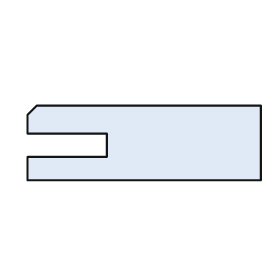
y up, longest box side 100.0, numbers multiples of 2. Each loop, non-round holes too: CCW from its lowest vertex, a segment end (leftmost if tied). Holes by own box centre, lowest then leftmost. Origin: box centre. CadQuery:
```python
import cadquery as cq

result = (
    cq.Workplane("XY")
    .moveTo(-50.0, -16.0)
    .lineTo(50.0, -16.0)
    .lineTo(50.0, 16.0)
    .lineTo(-46.0, 16.0)
    .lineTo(-50.0, 12.0)
    .lineTo(-50.0, 4.0)
    .lineTo(-16.0, 4.0)
    .lineTo(-16.0, -6.0)
    .lineTo(-50.0, -6.0)
    .close()
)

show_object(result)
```